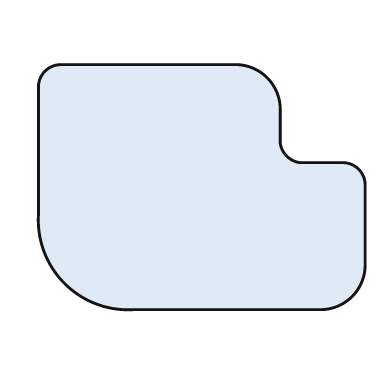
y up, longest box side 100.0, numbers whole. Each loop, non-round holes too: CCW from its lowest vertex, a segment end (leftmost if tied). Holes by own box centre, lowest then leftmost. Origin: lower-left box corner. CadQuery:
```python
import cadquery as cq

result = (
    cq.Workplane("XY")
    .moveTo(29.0, 0.0)
    .lineTo(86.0, 0.0)
    .threePointArc((96.0, 4.0), (100.0, 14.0))
    .lineTo(100.0, 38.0)
    .threePointArc((98.0, 43.0), (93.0, 45.0))
    .lineTo(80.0, 45.0)
    .threePointArc((76.0, 47.0), (74.0, 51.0))
    .lineTo(74.0, 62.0)
    .threePointArc((70.0, 71.0), (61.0, 75.0))
    .lineTo(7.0, 75.0)
    .threePointArc((2.0, 73.0), (0.0, 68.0))
    .lineTo(0.0, 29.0)
    .threePointArc((8.0, 8.0), (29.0, 0.0))
    .close()
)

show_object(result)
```